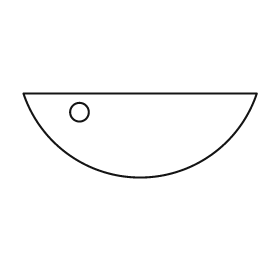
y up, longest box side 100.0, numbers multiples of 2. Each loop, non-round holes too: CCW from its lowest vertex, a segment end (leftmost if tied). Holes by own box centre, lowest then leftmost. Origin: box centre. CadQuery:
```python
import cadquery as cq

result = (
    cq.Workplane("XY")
    .moveTo(-50.0, 18.0)
    .threePointArc((0.0, -18.0), (50.0, 18.0))
    .close()
    .moveTo(-26.0, 10.0)
    .circle(4.0)
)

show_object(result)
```